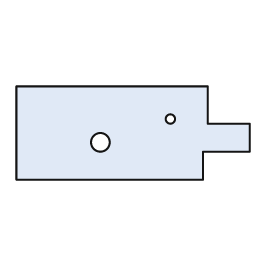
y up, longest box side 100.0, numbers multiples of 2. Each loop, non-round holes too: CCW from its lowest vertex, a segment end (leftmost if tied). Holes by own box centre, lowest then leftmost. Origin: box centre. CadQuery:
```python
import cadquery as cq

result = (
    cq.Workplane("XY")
    .moveTo(-50.0, -20.0)
    .lineTo(30.0, -20.0)
    .lineTo(30.0, -8.0)
    .lineTo(50.0, -8.0)
    .lineTo(50.0, 4.0)
    .lineTo(32.0, 4.0)
    .lineTo(32.0, 20.0)
    .lineTo(-50.0, 20.0)
    .close()
    .moveTo(-14.0, -4.0)
    .circle(4.0)
    .moveTo(16.0, 6.0)
    .circle(2.0)
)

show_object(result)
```